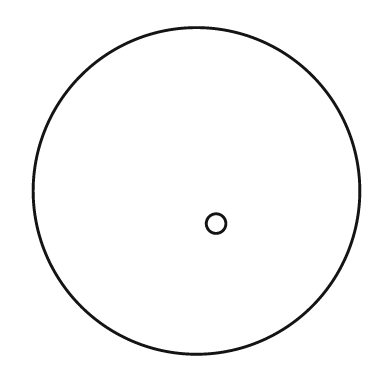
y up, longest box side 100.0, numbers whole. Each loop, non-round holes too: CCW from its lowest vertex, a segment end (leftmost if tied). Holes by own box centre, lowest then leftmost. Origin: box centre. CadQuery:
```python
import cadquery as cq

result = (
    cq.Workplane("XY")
    .moveTo(0.0, 0.0)
    .circle(50.0)
    .moveTo(6.0, -10.0)
    .circle(3.0)
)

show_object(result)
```